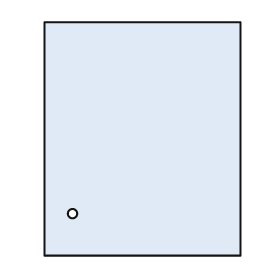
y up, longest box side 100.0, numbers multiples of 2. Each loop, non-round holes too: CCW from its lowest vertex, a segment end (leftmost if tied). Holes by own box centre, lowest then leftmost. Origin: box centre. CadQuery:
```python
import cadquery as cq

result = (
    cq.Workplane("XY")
    .moveTo(-42.0, -50.0)
    .lineTo(42.0, -50.0)
    .lineTo(42.0, 50.0)
    .lineTo(-42.0, 50.0)
    .close()
    .moveTo(-30.0, -32.0)
    .circle(2.0)
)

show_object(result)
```